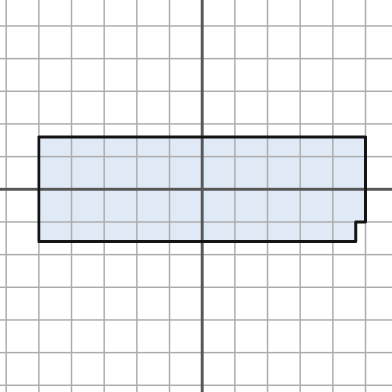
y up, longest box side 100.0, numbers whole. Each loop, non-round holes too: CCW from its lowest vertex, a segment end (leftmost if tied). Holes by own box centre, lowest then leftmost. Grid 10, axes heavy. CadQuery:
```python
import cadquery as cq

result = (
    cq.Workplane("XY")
    .moveTo(-50.0, -16.0)
    .lineTo(47.0, -16.0)
    .lineTo(47.0, -10.0)
    .lineTo(50.0, -10.0)
    .lineTo(50.0, 16.0)
    .lineTo(-50.0, 16.0)
    .close()
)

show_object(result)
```